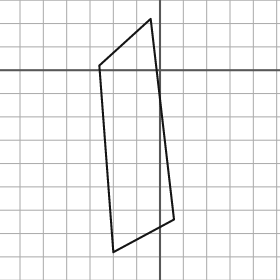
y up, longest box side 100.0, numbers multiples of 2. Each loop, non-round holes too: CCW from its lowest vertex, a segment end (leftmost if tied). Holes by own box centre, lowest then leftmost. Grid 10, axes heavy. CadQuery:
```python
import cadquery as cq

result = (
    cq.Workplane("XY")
    .moveTo(-20.0, -78.0)
    .lineTo(6.0, -64.0)
    .lineTo(-4.0, 22.0)
    .lineTo(-26.0, 2.0)
    .close()
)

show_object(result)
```